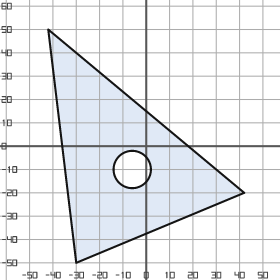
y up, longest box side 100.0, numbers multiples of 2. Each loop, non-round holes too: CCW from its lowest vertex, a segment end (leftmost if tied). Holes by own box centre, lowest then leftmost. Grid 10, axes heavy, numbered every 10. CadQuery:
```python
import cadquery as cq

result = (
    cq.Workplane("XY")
    .moveTo(-30.0, -50.0)
    .lineTo(42.0, -20.0)
    .lineTo(-42.0, 50.0)
    .close()
    .moveTo(-6.0, -10.0)
    .circle(8.0)
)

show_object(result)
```